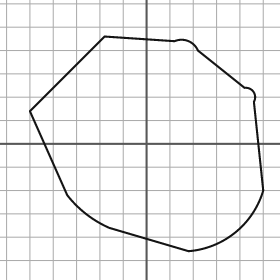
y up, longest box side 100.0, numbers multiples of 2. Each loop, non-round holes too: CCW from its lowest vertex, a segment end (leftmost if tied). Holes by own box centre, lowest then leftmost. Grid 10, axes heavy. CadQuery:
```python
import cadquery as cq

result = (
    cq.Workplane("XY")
    .moveTo(18.0, -46.0)
    .threePointArc((38.0, -38.0), (50.0, -20.0))
    .lineTo(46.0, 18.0)
    .threePointArc((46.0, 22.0), (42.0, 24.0))
    .lineTo(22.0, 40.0)
    .threePointArc((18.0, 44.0), (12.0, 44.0))
    .lineTo(-18.0, 46.0)
    .lineTo(-50.0, 14.0)
    .lineTo(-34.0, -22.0)
    .threePointArc((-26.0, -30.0), (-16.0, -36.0))
    .close()
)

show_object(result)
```